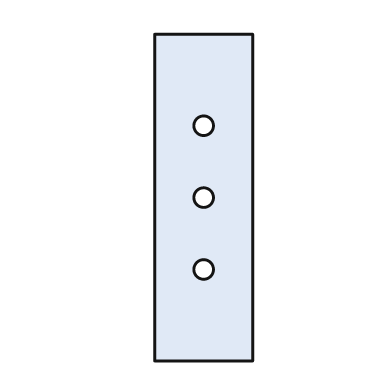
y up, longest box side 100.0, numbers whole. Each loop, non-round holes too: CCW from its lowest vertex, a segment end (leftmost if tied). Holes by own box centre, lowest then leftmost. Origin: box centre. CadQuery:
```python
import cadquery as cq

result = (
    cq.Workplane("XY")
    .moveTo(-15.0, -50.0)
    .lineTo(15.0, -50.0)
    .lineTo(15.0, 50.0)
    .lineTo(-15.0, 50.0)
    .close()
    .moveTo(0.0, -22.0)
    .circle(3.0)
    .moveTo(0.0, 0.0)
    .circle(3.0)
    .moveTo(0.0, 22.0)
    .circle(3.0)
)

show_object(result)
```